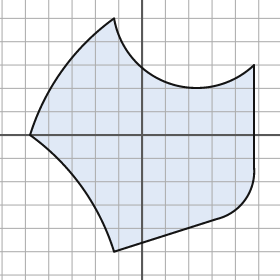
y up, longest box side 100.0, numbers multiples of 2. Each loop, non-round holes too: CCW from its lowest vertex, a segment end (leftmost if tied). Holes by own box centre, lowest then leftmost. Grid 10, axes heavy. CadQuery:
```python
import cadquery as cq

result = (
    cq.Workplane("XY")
    .moveTo(-12.0, -50.0)
    .lineTo(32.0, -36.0)
    .threePointArc((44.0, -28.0), (48.0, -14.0))
    .lineTo(48.0, 30.0)
    .threePointArc((12.0, 22.0), (-12.0, 50.0))
    .threePointArc((-34.0, 28.0), (-48.0, 0.0))
    .threePointArc((-26.0, -22.0), (-12.0, -50.0))
    .close()
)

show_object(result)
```